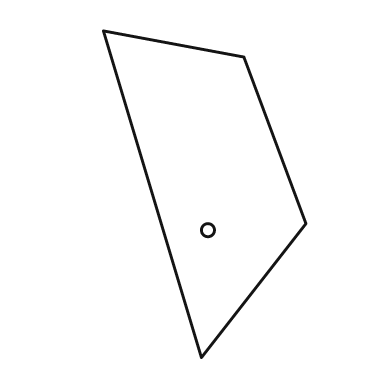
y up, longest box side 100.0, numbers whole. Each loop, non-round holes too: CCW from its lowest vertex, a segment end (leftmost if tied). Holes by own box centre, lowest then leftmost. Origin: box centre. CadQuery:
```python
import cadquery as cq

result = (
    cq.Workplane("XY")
    .moveTo(-1.0, -50.0)
    .lineTo(31.0, -9.0)
    .lineTo(12.0, 42.0)
    .lineTo(-31.0, 50.0)
    .close()
    .moveTo(1.0, -11.0)
    .circle(2.0)
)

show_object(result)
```